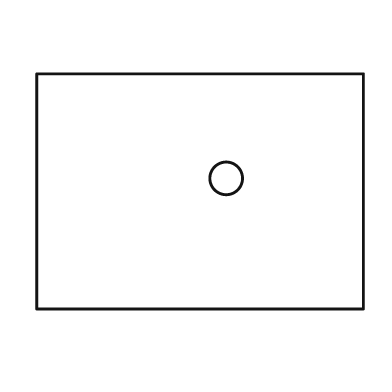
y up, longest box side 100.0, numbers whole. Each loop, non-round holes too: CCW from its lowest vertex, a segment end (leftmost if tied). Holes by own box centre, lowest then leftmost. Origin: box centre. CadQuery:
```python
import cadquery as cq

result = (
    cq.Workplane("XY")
    .moveTo(-50.0, -36.0)
    .lineTo(50.0, -36.0)
    .lineTo(50.0, 36.0)
    .lineTo(-50.0, 36.0)
    .close()
    .moveTo(8.0, 4.0)
    .circle(5.0)
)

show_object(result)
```